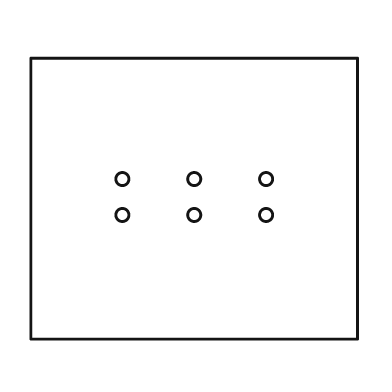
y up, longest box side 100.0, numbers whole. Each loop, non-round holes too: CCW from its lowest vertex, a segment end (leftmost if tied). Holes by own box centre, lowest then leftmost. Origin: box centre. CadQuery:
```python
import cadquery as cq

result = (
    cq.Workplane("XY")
    .moveTo(-50.0, -43.0)
    .lineTo(50.0, -43.0)
    .lineTo(50.0, 43.0)
    .lineTo(-50.0, 43.0)
    .close()
    .moveTo(-22.0, -5.0)
    .circle(2.0)
    .moveTo(0.0, -5.0)
    .circle(2.0)
    .moveTo(22.0, -5.0)
    .circle(2.0)
    .moveTo(-22.0, 6.0)
    .circle(2.0)
    .moveTo(0.0, 6.0)
    .circle(2.0)
    .moveTo(22.0, 6.0)
    .circle(2.0)
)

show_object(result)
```